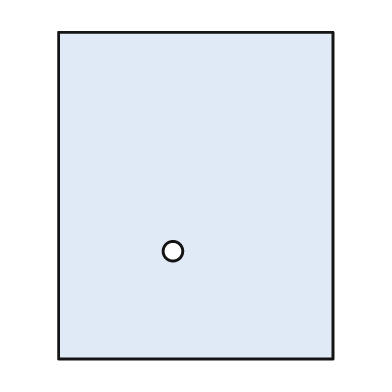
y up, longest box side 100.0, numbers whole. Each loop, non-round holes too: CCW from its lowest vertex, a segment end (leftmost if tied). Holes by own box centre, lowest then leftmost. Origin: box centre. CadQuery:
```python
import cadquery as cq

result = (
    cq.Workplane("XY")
    .moveTo(-42.0, -50.0)
    .lineTo(42.0, -50.0)
    .lineTo(42.0, 50.0)
    .lineTo(-42.0, 50.0)
    .close()
    .moveTo(-7.0, -17.0)
    .circle(3.0)
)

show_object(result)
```